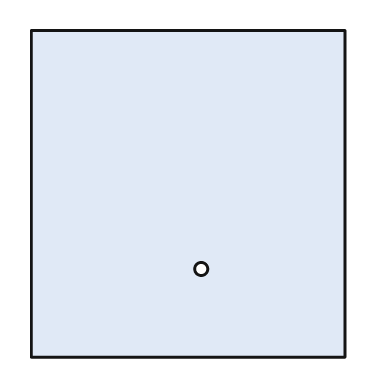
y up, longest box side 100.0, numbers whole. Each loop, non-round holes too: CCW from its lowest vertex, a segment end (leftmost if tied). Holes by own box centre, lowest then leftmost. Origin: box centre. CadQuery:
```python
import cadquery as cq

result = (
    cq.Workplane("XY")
    .moveTo(-48.0, -50.0)
    .lineTo(48.0, -50.0)
    .lineTo(48.0, 50.0)
    .lineTo(-48.0, 50.0)
    .close()
    .moveTo(4.0, -23.0)
    .circle(2.0)
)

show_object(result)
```